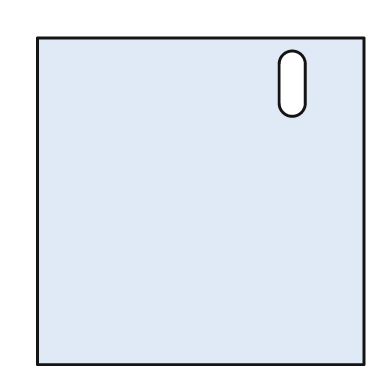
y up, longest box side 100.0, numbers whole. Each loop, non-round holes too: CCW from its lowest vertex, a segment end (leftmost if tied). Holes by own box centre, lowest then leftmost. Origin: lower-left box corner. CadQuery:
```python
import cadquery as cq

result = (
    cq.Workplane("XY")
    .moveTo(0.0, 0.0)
    .lineTo(100.0, 0.0)
    .lineTo(100.0, 100.0)
    .lineTo(0.0, 100.0)
    .close()
    .moveTo(74.0, 80.0)
    .threePointArc((78.0, 76.0), (82.0, 80.0))
    .lineTo(82.0, 92.0)
    .threePointArc((78.0, 96.0), (74.0, 92.0))
    .close()
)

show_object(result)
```